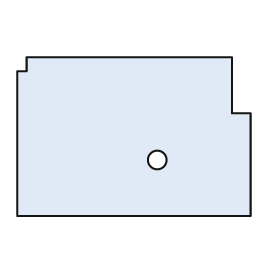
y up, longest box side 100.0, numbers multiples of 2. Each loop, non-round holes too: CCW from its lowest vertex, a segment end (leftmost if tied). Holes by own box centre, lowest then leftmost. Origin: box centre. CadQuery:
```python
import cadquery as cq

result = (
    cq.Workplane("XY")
    .moveTo(-50.0, -34.0)
    .lineTo(50.0, -34.0)
    .lineTo(50.0, 10.0)
    .lineTo(42.0, 10.0)
    .lineTo(42.0, 34.0)
    .lineTo(-46.0, 34.0)
    .lineTo(-46.0, 28.0)
    .lineTo(-50.0, 28.0)
    .close()
    .moveTo(10.0, -10.0)
    .circle(4.0)
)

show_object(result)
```